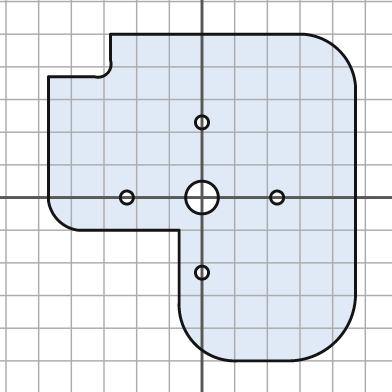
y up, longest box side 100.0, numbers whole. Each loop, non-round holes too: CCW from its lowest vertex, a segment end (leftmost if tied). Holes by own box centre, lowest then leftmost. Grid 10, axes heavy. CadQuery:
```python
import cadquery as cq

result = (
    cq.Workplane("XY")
    .moveTo(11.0, -50.0)
    .lineTo(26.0, -50.0)
    .threePointArc((41.0, -44.0), (47.0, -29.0))
    .lineTo(47.0, 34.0)
    .threePointArc((42.0, 45.0), (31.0, 50.0))
    .lineTo(-28.0, 50.0)
    .lineTo(-28.0, 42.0)
    .threePointArc((-29.0, 38.0), (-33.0, 37.0))
    .lineTo(-47.0, 37.0)
    .lineTo(-47.0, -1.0)
    .threePointArc((-44.0, -7.0), (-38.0, -10.0))
    .lineTo(-7.0, -10.0)
    .lineTo(-7.0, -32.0)
    .threePointArc((-2.0, -45.0), (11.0, -50.0))
    .close()
    .moveTo(0.0, -23.0)
    .circle(2.0)
    .moveTo(-23.0, 0.0)
    .circle(2.0)
    .moveTo(0.0, 0.0)
    .circle(5.0)
    .moveTo(23.0, 0.0)
    .circle(2.0)
    .moveTo(0.0, 23.0)
    .circle(2.0)
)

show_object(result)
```